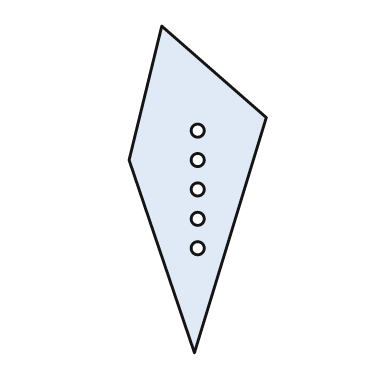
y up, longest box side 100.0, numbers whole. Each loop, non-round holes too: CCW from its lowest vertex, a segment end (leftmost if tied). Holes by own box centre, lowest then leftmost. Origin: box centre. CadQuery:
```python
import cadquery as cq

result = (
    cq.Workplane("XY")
    .moveTo(-1.0, -50.0)
    .lineTo(21.0, 22.0)
    .lineTo(-11.0, 50.0)
    .lineTo(-21.0, 9.0)
    .close()
    .moveTo(0.0, -18.0)
    .circle(2.0)
    .moveTo(0.0, -9.0)
    .circle(2.0)
    .moveTo(0.0, 0.0)
    .circle(2.0)
    .moveTo(0.0, 9.0)
    .circle(2.0)
    .moveTo(0.0, 18.0)
    .circle(2.0)
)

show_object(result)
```